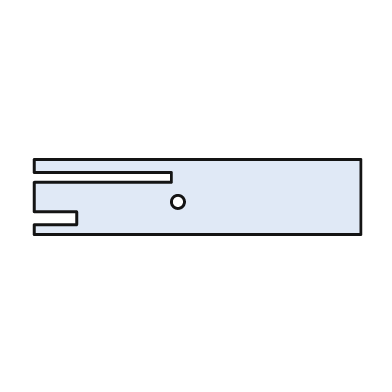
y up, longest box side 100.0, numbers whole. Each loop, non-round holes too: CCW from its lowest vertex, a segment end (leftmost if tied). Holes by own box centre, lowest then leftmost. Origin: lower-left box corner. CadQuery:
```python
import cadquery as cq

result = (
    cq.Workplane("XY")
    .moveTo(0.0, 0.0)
    .lineTo(100.0, 0.0)
    .lineTo(100.0, 23.0)
    .lineTo(0.0, 23.0)
    .lineTo(0.0, 19.0)
    .lineTo(42.0, 19.0)
    .lineTo(42.0, 16.0)
    .lineTo(0.0, 16.0)
    .lineTo(0.0, 7.0)
    .lineTo(13.0, 7.0)
    .lineTo(13.0, 3.0)
    .lineTo(0.0, 3.0)
    .close()
    .moveTo(44.0, 10.0)
    .circle(2.0)
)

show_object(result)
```